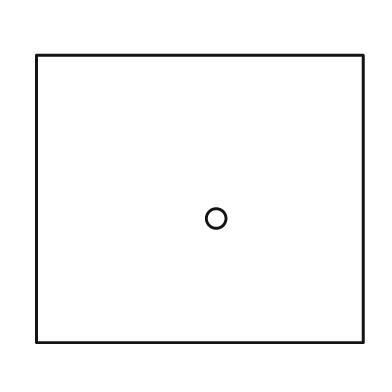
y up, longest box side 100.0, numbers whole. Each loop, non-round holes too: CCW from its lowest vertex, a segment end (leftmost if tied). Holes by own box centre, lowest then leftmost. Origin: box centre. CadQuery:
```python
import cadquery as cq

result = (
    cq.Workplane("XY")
    .moveTo(-50.0, -44.0)
    .lineTo(50.0, -44.0)
    .lineTo(50.0, 44.0)
    .lineTo(-50.0, 44.0)
    .close()
    .moveTo(5.0, -6.0)
    .circle(3.0)
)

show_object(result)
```